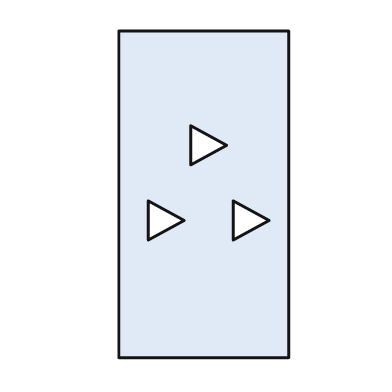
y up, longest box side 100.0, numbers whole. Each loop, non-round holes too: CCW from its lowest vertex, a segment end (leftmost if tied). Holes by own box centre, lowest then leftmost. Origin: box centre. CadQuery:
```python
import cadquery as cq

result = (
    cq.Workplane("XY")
    .moveTo(-26.0, -50.0)
    .lineTo(26.0, -50.0)
    .lineTo(26.0, 50.0)
    .lineTo(-26.0, 50.0)
    .close()
    .moveTo(-17.0, -14.0)
    .lineTo(-6.0, -8.0)
    .lineTo(-17.0, -2.0)
    .close()
    .moveTo(9.0, -14.0)
    .lineTo(20.0, -8.0)
    .lineTo(9.0, -2.0)
    .close()
    .moveTo(-4.0, 9.0)
    .lineTo(7.0, 15.0)
    .lineTo(-4.0, 21.0)
    .close()
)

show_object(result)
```